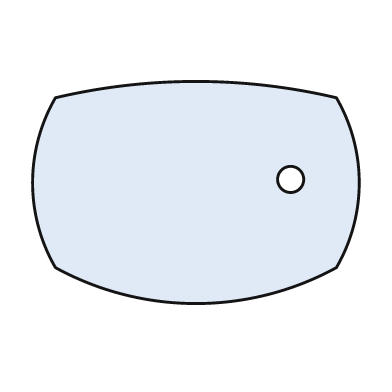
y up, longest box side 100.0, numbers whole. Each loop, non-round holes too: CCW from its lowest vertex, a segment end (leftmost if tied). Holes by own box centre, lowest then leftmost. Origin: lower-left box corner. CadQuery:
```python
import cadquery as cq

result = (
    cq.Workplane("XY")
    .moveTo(7.0, 11.0)
    .threePointArc((50.0, 0.0), (93.0, 11.0))
    .threePointArc((100.0, 37.0), (93.0, 63.0))
    .threePointArc((50.0, 68.0), (7.0, 63.0))
    .threePointArc((0.0, 37.0), (7.0, 11.0))
    .close()
    .moveTo(79.0, 38.0)
    .circle(4.0)
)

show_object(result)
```